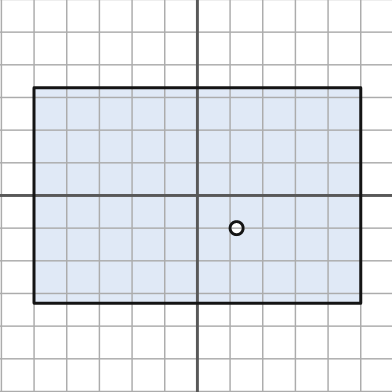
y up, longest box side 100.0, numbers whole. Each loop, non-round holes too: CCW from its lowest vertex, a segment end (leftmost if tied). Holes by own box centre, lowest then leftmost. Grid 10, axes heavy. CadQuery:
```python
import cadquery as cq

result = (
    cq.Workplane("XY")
    .moveTo(-50.0, -33.0)
    .lineTo(50.0, -33.0)
    .lineTo(50.0, 33.0)
    .lineTo(-50.0, 33.0)
    .close()
    .moveTo(12.0, -10.0)
    .circle(2.0)
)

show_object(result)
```